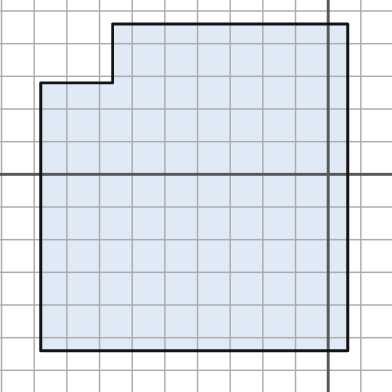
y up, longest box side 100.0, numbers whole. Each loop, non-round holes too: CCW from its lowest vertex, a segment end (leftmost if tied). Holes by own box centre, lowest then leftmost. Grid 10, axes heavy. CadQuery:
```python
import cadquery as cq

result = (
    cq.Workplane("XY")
    .moveTo(-88.0, -54.0)
    .lineTo(6.0, -54.0)
    .lineTo(6.0, 46.0)
    .lineTo(-66.0, 46.0)
    .lineTo(-66.0, 28.0)
    .lineTo(-88.0, 28.0)
    .close()
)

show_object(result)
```